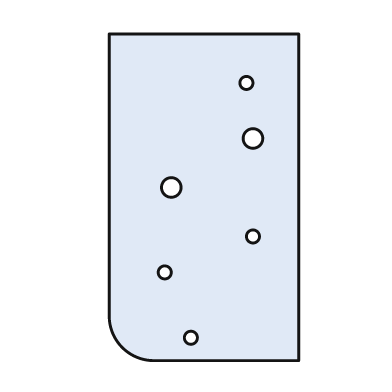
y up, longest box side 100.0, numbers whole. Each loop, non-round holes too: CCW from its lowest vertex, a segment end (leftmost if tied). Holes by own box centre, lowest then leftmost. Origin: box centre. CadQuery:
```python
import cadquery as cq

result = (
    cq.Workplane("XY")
    .moveTo(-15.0, -50.0)
    .lineTo(29.0, -50.0)
    .lineTo(29.0, 50.0)
    .lineTo(-29.0, 50.0)
    .lineTo(-29.0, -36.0)
    .threePointArc((-25.0, -46.0), (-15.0, -50.0))
    .close()
    .moveTo(-4.0, -43.0)
    .circle(2.0)
    .moveTo(-12.0, -23.0)
    .circle(2.0)
    .moveTo(15.0, -12.0)
    .circle(2.0)
    .moveTo(-10.0, 3.0)
    .circle(3.0)
    .moveTo(15.0, 18.0)
    .circle(3.0)
    .moveTo(13.0, 35.0)
    .circle(2.0)
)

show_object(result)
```